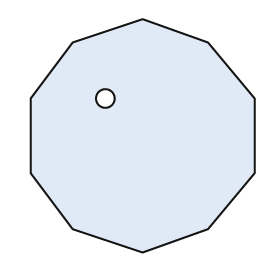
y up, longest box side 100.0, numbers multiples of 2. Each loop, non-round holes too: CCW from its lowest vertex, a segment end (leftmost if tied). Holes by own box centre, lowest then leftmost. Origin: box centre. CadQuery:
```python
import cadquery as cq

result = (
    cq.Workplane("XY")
    .moveTo(0.0, -50.0)
    .lineTo(28.0, -40.0)
    .lineTo(48.0, -16.0)
    .lineTo(48.0, 16.0)
    .lineTo(28.0, 40.0)
    .lineTo(0.0, 50.0)
    .lineTo(-30.0, 40.0)
    .lineTo(-48.0, 16.0)
    .lineTo(-48.0, -16.0)
    .lineTo(-30.0, -40.0)
    .close()
    .moveTo(-16.0, 16.0)
    .circle(4.0)
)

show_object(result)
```